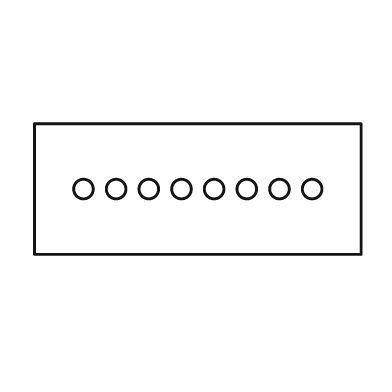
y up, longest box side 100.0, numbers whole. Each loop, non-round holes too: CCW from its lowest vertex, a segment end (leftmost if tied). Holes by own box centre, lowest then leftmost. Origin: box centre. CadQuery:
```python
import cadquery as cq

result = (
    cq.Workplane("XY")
    .moveTo(-50.0, -20.0)
    .lineTo(50.0, -20.0)
    .lineTo(50.0, 20.0)
    .lineTo(-50.0, 20.0)
    .close()
    .moveTo(-35.0, 0.0)
    .circle(3.0)
    .moveTo(-25.0, 0.0)
    .circle(3.0)
    .moveTo(-15.0, 0.0)
    .circle(3.0)
    .moveTo(-5.0, 0.0)
    .circle(3.0)
    .moveTo(5.0, 0.0)
    .circle(3.0)
    .moveTo(15.0, 0.0)
    .circle(3.0)
    .moveTo(25.0, 0.0)
    .circle(3.0)
    .moveTo(35.0, 0.0)
    .circle(3.0)
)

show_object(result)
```